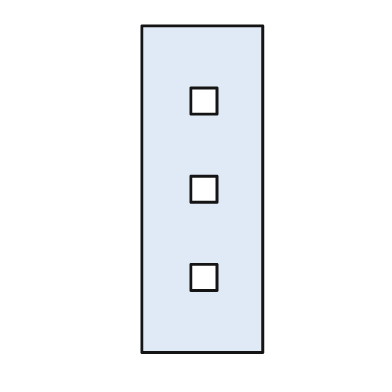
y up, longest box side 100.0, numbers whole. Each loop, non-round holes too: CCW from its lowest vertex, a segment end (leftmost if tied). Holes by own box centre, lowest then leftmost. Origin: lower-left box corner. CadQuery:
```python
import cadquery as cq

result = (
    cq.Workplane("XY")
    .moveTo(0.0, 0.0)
    .lineTo(37.0, 0.0)
    .lineTo(37.0, 100.0)
    .lineTo(0.0, 100.0)
    .close()
    .moveTo(15.0, 19.0)
    .lineTo(23.0, 19.0)
    .lineTo(23.0, 27.0)
    .lineTo(15.0, 27.0)
    .close()
    .moveTo(15.0, 46.0)
    .lineTo(23.0, 46.0)
    .lineTo(23.0, 54.0)
    .lineTo(15.0, 54.0)
    .close()
    .moveTo(15.0, 73.0)
    .lineTo(23.0, 73.0)
    .lineTo(23.0, 81.0)
    .lineTo(15.0, 81.0)
    .close()
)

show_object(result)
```